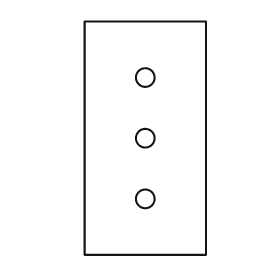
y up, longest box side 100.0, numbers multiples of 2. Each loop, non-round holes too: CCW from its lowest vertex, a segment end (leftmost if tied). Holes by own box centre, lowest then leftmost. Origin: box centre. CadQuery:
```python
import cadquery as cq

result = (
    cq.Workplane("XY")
    .moveTo(-26.0, -50.0)
    .lineTo(26.0, -50.0)
    .lineTo(26.0, 50.0)
    .lineTo(-26.0, 50.0)
    .close()
    .moveTo(0.0, -26.0)
    .circle(4.0)
    .moveTo(0.0, 0.0)
    .circle(4.0)
    .moveTo(0.0, 26.0)
    .circle(4.0)
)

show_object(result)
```